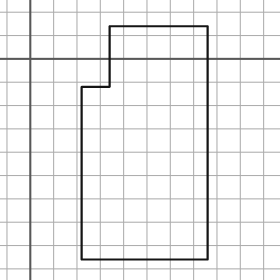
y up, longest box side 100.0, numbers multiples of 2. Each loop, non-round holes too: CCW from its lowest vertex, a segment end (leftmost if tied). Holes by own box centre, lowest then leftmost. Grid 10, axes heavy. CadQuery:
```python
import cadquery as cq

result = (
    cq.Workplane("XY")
    .moveTo(22.0, -86.0)
    .lineTo(76.0, -86.0)
    .lineTo(76.0, 14.0)
    .lineTo(34.0, 14.0)
    .lineTo(34.0, -12.0)
    .lineTo(22.0, -12.0)
    .close()
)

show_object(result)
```